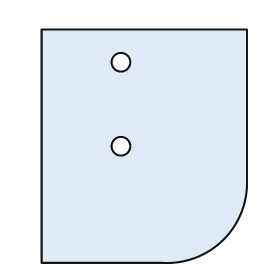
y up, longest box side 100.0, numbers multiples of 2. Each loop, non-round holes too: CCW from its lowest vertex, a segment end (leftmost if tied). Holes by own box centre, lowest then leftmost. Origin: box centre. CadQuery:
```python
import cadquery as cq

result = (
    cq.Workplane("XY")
    .moveTo(-44.0, -50.0)
    .lineTo(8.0, -50.0)
    .threePointArc((34.0, -40.0), (44.0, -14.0))
    .lineTo(44.0, 50.0)
    .lineTo(-44.0, 50.0)
    .close()
    .moveTo(-10.0, 0.0)
    .circle(4.0)
    .moveTo(-10.0, 36.0)
    .circle(4.0)
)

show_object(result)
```